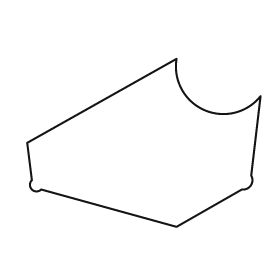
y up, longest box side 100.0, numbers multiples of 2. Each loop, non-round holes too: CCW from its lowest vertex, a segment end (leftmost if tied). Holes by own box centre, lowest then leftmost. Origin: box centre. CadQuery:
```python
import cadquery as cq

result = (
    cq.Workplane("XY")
    .moveTo(14.0, -36.0)
    .lineTo(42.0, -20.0)
    .threePointArc((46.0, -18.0), (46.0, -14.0))
    .lineTo(50.0, 20.0)
    .threePointArc((26.0, 14.0), (14.0, 36.0))
    .lineTo(-50.0, 0.0)
    .lineTo(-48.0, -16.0)
    .threePointArc((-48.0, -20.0), (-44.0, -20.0))
    .close()
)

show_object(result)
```